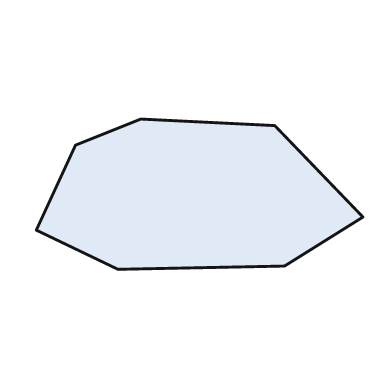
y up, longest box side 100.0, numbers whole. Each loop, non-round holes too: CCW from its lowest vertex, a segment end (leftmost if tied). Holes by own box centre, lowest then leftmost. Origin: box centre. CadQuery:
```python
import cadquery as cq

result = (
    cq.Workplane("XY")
    .moveTo(-25.0, -23.0)
    .lineTo(26.0, -22.0)
    .lineTo(50.0, -7.0)
    .lineTo(23.0, 21.0)
    .lineTo(-18.0, 23.0)
    .lineTo(-38.0, 15.0)
    .lineTo(-50.0, -11.0)
    .close()
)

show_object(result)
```